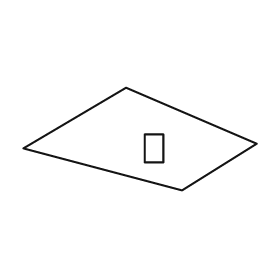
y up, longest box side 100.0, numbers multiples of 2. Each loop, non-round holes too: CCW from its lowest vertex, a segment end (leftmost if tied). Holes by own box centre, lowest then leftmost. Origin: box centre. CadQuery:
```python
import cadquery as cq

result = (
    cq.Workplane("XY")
    .moveTo(18.0, -22.0)
    .lineTo(50.0, -2.0)
    .lineTo(-6.0, 22.0)
    .lineTo(-50.0, -4.0)
    .close()
    .moveTo(2.0, -10.0)
    .lineTo(10.0, -10.0)
    .lineTo(10.0, 2.0)
    .lineTo(2.0, 2.0)
    .close()
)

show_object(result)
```